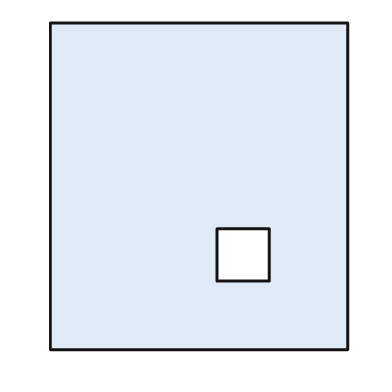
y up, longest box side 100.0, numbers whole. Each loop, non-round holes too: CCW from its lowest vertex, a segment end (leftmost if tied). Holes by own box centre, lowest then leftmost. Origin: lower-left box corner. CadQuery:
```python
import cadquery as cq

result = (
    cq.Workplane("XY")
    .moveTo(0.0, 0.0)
    .lineTo(91.0, 0.0)
    .lineTo(91.0, 100.0)
    .lineTo(0.0, 100.0)
    .close()
    .moveTo(51.0, 21.0)
    .lineTo(67.0, 21.0)
    .lineTo(67.0, 37.0)
    .lineTo(51.0, 37.0)
    .close()
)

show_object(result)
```